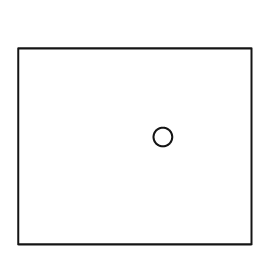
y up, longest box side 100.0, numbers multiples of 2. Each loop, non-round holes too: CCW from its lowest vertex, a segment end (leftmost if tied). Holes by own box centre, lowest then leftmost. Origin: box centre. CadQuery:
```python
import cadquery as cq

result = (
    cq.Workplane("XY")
    .moveTo(-50.0, -42.0)
    .lineTo(50.0, -42.0)
    .lineTo(50.0, 42.0)
    .lineTo(-50.0, 42.0)
    .close()
    .moveTo(12.0, 4.0)
    .circle(4.0)
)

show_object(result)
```